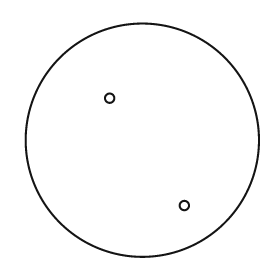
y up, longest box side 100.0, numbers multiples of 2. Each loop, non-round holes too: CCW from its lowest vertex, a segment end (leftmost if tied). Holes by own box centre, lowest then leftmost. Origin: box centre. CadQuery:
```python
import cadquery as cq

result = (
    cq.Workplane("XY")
    .moveTo(0.0, 0.0)
    .circle(50.0)
    .moveTo(18.0, -28.0)
    .circle(2.0)
    .moveTo(-14.0, 18.0)
    .circle(2.0)
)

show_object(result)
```